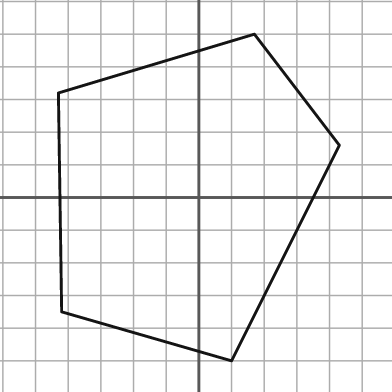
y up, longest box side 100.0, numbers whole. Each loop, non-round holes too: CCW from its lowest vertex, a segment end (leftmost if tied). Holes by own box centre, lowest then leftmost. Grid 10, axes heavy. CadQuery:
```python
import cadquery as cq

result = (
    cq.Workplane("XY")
    .moveTo(10.0, -50.0)
    .lineTo(43.0, 16.0)
    .lineTo(17.0, 50.0)
    .lineTo(-43.0, 32.0)
    .lineTo(-42.0, -35.0)
    .close()
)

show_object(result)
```